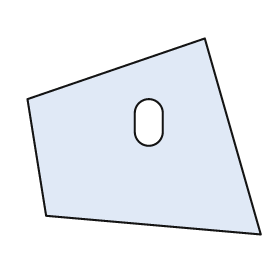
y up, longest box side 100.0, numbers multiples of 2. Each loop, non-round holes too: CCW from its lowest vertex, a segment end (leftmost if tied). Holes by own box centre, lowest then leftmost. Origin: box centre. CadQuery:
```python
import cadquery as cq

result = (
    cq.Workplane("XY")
    .moveTo(50.0, -42.0)
    .lineTo(26.0, 42.0)
    .lineTo(-50.0, 16.0)
    .lineTo(-42.0, -34.0)
    .close()
    .moveTo(-4.0, 2.0)
    .threePointArc((2.0, -4.0), (8.0, 2.0))
    .lineTo(8.0, 10.0)
    .threePointArc((2.0, 16.0), (-4.0, 10.0))
    .close()
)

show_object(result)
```